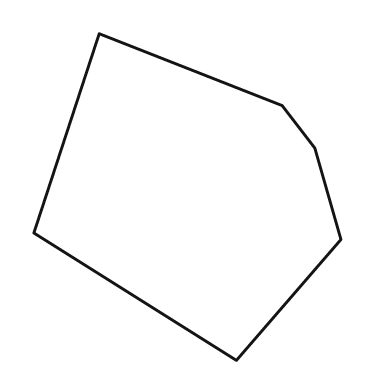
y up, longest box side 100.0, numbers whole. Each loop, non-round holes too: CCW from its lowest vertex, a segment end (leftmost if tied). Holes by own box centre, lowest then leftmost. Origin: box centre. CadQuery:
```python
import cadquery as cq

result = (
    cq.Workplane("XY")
    .moveTo(15.0, -50.0)
    .lineTo(47.0, -13.0)
    .lineTo(39.0, 15.0)
    .lineTo(29.0, 28.0)
    .lineTo(-27.0, 50.0)
    .lineTo(-47.0, -11.0)
    .close()
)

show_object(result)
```